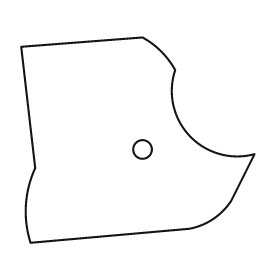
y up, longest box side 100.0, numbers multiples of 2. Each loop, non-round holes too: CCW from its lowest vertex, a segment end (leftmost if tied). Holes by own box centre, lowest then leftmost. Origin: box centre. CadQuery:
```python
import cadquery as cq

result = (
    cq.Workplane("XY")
    .moveTo(-46.0, -44.0)
    .lineTo(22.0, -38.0)
    .threePointArc((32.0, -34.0), (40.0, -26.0))
    .lineTo(50.0, -6.0)
    .threePointArc((22.0, 2.0), (16.0, 30.0))
    .threePointArc((10.0, 38.0), (2.0, 44.0))
    .lineTo(-50.0, 40.0)
    .lineTo(-44.0, -12.0)
    .threePointArc((-48.0, -28.0), (-46.0, -44.0))
    .close()
    .moveTo(2.0, -4.0)
    .circle(4.0)
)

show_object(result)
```